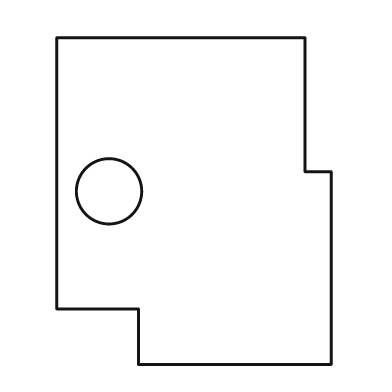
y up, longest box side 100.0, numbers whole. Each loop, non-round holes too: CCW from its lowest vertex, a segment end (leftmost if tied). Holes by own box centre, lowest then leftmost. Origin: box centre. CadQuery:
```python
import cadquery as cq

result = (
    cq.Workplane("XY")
    .moveTo(-17.0, -50.0)
    .lineTo(42.0, -50.0)
    .lineTo(42.0, 9.0)
    .lineTo(34.0, 9.0)
    .lineTo(34.0, 50.0)
    .lineTo(-42.0, 50.0)
    .lineTo(-42.0, -33.0)
    .lineTo(-17.0, -33.0)
    .close()
    .moveTo(-26.0, 3.0)
    .circle(10.0)
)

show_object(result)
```